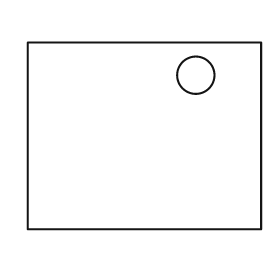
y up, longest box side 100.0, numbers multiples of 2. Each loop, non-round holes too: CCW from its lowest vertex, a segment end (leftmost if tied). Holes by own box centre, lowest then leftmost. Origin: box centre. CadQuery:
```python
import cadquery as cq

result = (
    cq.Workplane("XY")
    .moveTo(-50.0, -40.0)
    .lineTo(50.0, -40.0)
    .lineTo(50.0, 40.0)
    .lineTo(-50.0, 40.0)
    .close()
    .moveTo(22.0, 26.0)
    .circle(8.0)
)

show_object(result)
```